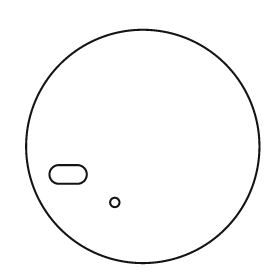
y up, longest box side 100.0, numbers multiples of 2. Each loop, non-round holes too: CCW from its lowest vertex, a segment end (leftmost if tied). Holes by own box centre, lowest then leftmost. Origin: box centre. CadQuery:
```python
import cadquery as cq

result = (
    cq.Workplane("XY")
    .moveTo(0.0, 0.0)
    .circle(50.0)
    .moveTo(-12.0, -24.0)
    .circle(2.0)
    .moveTo(-36.0, -16.0)
    .lineTo(-28.0, -16.0)
    .threePointArc((-24.0, -12.0), (-28.0, -8.0))
    .lineTo(-36.0, -8.0)
    .threePointArc((-40.0, -12.0), (-36.0, -16.0))
    .close()
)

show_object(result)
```